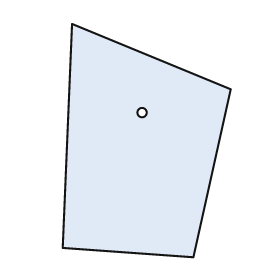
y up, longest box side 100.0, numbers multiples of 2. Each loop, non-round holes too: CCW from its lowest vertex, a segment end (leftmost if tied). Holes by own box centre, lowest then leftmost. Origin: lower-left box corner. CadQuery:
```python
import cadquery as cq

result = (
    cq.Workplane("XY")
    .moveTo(56.0, 0.0)
    .lineTo(72.0, 72.0)
    .lineTo(4.0, 100.0)
    .lineTo(0.0, 4.0)
    .close()
    .moveTo(34.0, 62.0)
    .circle(2.0)
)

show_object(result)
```